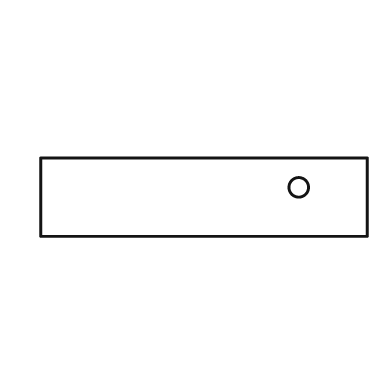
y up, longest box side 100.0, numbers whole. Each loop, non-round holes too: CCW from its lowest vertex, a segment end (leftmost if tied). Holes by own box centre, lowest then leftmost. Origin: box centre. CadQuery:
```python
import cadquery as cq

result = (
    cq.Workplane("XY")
    .moveTo(-50.0, -12.0)
    .lineTo(50.0, -12.0)
    .lineTo(50.0, 12.0)
    .lineTo(-50.0, 12.0)
    .close()
    .moveTo(29.0, 3.0)
    .circle(3.0)
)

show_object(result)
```